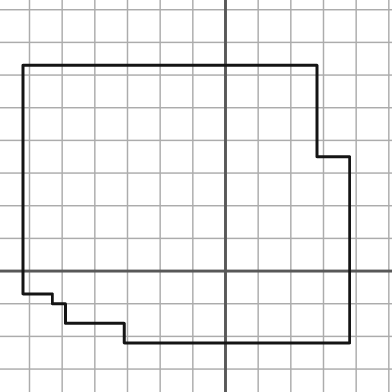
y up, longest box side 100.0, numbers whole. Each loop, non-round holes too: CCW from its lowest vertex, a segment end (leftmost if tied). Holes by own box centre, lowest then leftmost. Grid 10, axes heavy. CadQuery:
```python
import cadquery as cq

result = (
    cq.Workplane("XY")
    .moveTo(-31.0, -22.0)
    .lineTo(38.0, -22.0)
    .lineTo(38.0, 35.0)
    .lineTo(28.0, 35.0)
    .lineTo(28.0, 63.0)
    .lineTo(-62.0, 63.0)
    .lineTo(-62.0, -7.0)
    .lineTo(-53.0, -7.0)
    .lineTo(-53.0, -10.0)
    .lineTo(-49.0, -10.0)
    .lineTo(-49.0, -16.0)
    .lineTo(-31.0, -16.0)
    .close()
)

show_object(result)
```